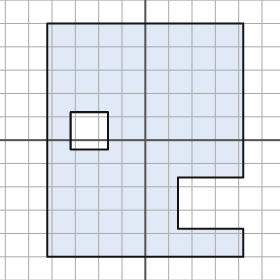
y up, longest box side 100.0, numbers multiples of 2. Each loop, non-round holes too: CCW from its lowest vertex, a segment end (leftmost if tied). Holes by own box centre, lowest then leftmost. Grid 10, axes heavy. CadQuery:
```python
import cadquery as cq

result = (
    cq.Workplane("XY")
    .moveTo(-42.0, -50.0)
    .lineTo(42.0, -50.0)
    .lineTo(42.0, -38.0)
    .lineTo(14.0, -38.0)
    .lineTo(14.0, -16.0)
    .lineTo(42.0, -16.0)
    .lineTo(42.0, 50.0)
    .lineTo(-42.0, 50.0)
    .close()
    .moveTo(-32.0, -4.0)
    .lineTo(-16.0, -4.0)
    .lineTo(-16.0, 12.0)
    .lineTo(-32.0, 12.0)
    .close()
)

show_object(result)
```